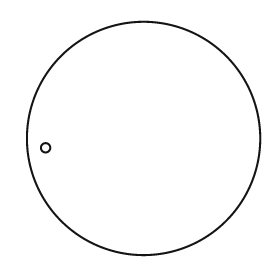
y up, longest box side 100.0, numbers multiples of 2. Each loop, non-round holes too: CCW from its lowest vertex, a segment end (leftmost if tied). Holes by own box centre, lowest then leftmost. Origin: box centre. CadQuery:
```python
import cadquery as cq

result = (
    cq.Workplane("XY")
    .moveTo(0.0, 0.0)
    .circle(50.0)
    .moveTo(-42.0, -4.0)
    .circle(2.0)
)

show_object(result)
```